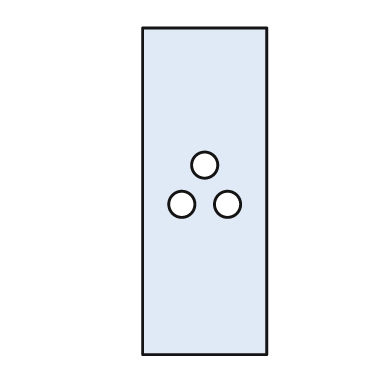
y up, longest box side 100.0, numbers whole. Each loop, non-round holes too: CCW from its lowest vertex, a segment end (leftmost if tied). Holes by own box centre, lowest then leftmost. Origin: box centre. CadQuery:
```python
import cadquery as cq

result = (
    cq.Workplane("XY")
    .moveTo(-19.0, -50.0)
    .lineTo(19.0, -50.0)
    .lineTo(19.0, 50.0)
    .lineTo(-19.0, 50.0)
    .close()
    .moveTo(-7.0, -4.0)
    .circle(4.0)
    .moveTo(7.0, -4.0)
    .circle(4.0)
    .moveTo(0.0, 8.0)
    .circle(4.0)
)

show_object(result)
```